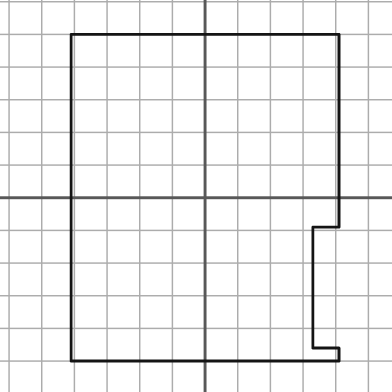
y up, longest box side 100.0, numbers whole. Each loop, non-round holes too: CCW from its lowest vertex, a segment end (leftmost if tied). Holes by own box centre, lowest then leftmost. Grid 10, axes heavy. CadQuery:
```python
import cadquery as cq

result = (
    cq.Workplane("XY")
    .moveTo(-41.0, -50.0)
    .lineTo(41.0, -50.0)
    .lineTo(41.0, -46.0)
    .lineTo(33.0, -46.0)
    .lineTo(33.0, -9.0)
    .lineTo(41.0, -9.0)
    .lineTo(41.0, 50.0)
    .lineTo(-41.0, 50.0)
    .close()
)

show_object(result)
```